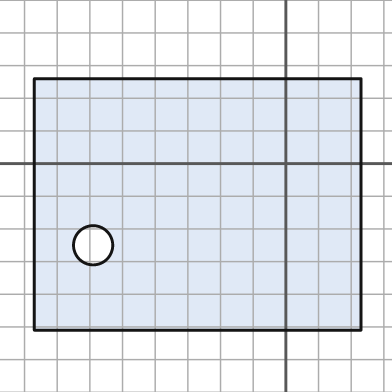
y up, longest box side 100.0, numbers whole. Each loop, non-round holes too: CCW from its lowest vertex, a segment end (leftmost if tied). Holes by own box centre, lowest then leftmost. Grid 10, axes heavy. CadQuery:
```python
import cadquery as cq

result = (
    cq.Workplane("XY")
    .moveTo(-77.0, -51.0)
    .lineTo(23.0, -51.0)
    .lineTo(23.0, 26.0)
    .lineTo(-77.0, 26.0)
    .close()
    .moveTo(-59.0, -25.0)
    .circle(6.0)
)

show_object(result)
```